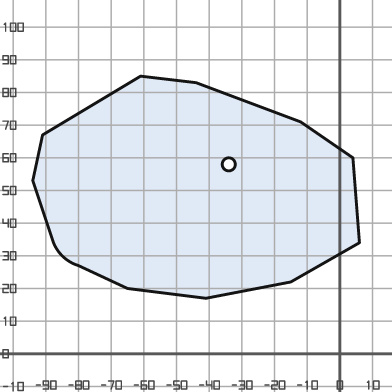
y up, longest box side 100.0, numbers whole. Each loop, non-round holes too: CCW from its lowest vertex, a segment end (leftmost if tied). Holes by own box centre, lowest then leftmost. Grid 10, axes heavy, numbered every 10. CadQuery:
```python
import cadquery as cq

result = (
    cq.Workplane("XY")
    .moveTo(-41.0, 17.0)
    .lineTo(-15.0, 22.0)
    .lineTo(6.0, 34.0)
    .lineTo(4.0, 60.0)
    .lineTo(-12.0, 71.0)
    .lineTo(-44.0, 83.0)
    .lineTo(-61.0, 85.0)
    .lineTo(-91.0, 67.0)
    .lineTo(-94.0, 53.0)
    .lineTo(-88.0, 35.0)
    .threePointArc((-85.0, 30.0), (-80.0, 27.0))
    .lineTo(-65.0, 20.0)
    .close()
    .moveTo(-34.0, 58.0)
    .circle(2.0)
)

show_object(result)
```